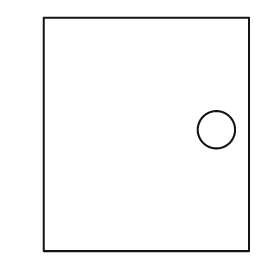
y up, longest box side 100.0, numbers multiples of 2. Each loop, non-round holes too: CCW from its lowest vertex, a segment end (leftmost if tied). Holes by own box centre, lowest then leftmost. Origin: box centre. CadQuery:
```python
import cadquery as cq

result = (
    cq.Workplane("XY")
    .moveTo(-44.0, -50.0)
    .lineTo(44.0, -50.0)
    .lineTo(44.0, 50.0)
    .lineTo(-44.0, 50.0)
    .close()
    .moveTo(30.0, 2.0)
    .circle(8.0)
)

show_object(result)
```